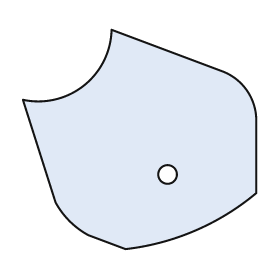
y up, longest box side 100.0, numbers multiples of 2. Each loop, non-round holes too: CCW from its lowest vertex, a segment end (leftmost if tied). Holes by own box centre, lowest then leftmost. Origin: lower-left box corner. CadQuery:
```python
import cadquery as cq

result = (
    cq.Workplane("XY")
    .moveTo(44.0, 0.0)
    .threePointArc((74.0, 8.0), (100.0, 24.0))
    .lineTo(100.0, 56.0)
    .threePointArc((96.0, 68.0), (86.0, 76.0))
    .lineTo(38.0, 94.0)
    .threePointArc((26.0, 70.0), (0.0, 64.0))
    .lineTo(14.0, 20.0)
    .threePointArc((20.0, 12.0), (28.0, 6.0))
    .close()
    .moveTo(62.0, 32.0)
    .circle(4.0)
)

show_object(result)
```